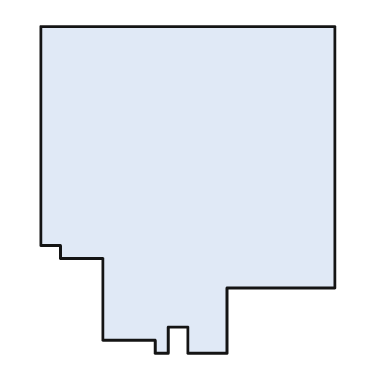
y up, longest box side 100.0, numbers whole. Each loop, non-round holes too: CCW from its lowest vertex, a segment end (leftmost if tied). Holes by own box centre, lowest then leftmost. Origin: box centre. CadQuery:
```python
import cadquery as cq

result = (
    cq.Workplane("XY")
    .moveTo(-10.0, -50.0)
    .lineTo(-6.0, -50.0)
    .lineTo(-6.0, -42.0)
    .lineTo(0.0, -42.0)
    .lineTo(0.0, -50.0)
    .lineTo(12.0, -50.0)
    .lineTo(12.0, -30.0)
    .lineTo(45.0, -30.0)
    .lineTo(45.0, 50.0)
    .lineTo(-45.0, 50.0)
    .lineTo(-45.0, -17.0)
    .lineTo(-39.0, -17.0)
    .lineTo(-39.0, -21.0)
    .lineTo(-26.0, -21.0)
    .lineTo(-26.0, -46.0)
    .lineTo(-10.0, -46.0)
    .close()
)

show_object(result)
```